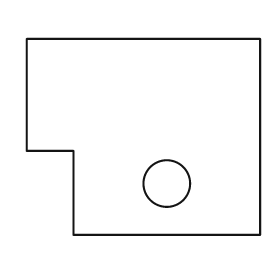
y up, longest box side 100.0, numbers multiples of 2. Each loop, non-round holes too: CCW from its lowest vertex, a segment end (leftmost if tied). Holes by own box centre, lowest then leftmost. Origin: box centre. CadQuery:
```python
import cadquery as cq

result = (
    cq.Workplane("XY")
    .moveTo(-30.0, -42.0)
    .lineTo(50.0, -42.0)
    .lineTo(50.0, 42.0)
    .lineTo(-50.0, 42.0)
    .lineTo(-50.0, -6.0)
    .lineTo(-30.0, -6.0)
    .close()
    .moveTo(10.0, -20.0)
    .circle(10.0)
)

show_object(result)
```